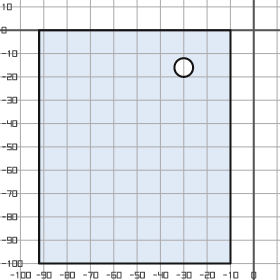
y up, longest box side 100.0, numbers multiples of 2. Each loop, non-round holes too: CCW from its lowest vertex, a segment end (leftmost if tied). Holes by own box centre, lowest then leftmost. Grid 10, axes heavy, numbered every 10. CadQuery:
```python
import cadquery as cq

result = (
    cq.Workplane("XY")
    .moveTo(-92.0, -100.0)
    .lineTo(-10.0, -100.0)
    .lineTo(-10.0, 0.0)
    .lineTo(-92.0, 0.0)
    .close()
    .moveTo(-30.0, -16.0)
    .circle(4.0)
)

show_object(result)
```